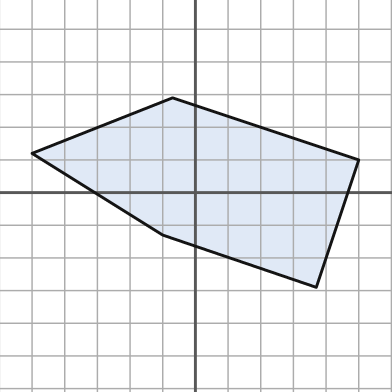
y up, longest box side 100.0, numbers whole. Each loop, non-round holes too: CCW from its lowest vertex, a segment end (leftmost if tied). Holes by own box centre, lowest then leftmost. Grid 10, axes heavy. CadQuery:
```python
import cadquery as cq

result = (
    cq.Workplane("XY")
    .moveTo(37.0, -29.0)
    .lineTo(50.0, 10.0)
    .lineTo(-7.0, 29.0)
    .lineTo(-50.0, 12.0)
    .lineTo(-10.0, -13.0)
    .close()
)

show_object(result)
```